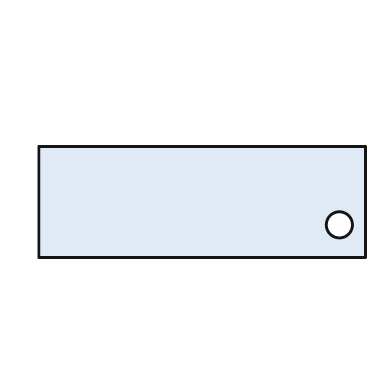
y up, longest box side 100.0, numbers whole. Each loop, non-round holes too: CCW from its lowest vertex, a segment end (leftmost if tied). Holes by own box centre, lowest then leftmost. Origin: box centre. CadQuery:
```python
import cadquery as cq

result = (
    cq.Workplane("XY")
    .moveTo(-50.0, -17.0)
    .lineTo(50.0, -17.0)
    .lineTo(50.0, 17.0)
    .lineTo(-50.0, 17.0)
    .close()
    .moveTo(42.0, -7.0)
    .circle(4.0)
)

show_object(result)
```